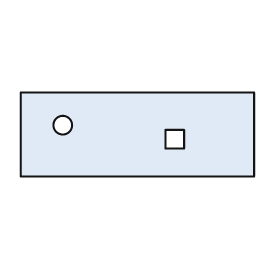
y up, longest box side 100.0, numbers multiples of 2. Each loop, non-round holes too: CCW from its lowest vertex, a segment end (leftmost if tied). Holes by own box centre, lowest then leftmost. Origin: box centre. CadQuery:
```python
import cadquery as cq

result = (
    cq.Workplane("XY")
    .moveTo(-50.0, -18.0)
    .lineTo(50.0, -18.0)
    .lineTo(50.0, 18.0)
    .lineTo(-50.0, 18.0)
    .close()
    .moveTo(12.0, -6.0)
    .lineTo(20.0, -6.0)
    .lineTo(20.0, 2.0)
    .lineTo(12.0, 2.0)
    .close()
    .moveTo(-32.0, 4.0)
    .circle(4.0)
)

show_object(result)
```